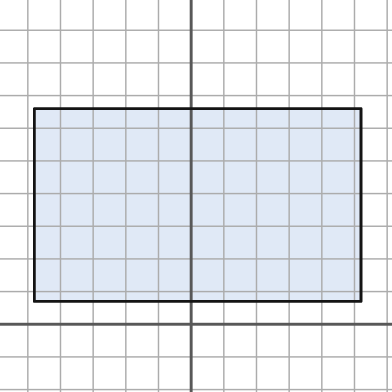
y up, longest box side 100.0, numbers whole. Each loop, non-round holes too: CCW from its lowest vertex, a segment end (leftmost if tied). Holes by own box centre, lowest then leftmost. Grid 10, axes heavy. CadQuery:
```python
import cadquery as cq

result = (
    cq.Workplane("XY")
    .moveTo(-48.0, 7.0)
    .lineTo(52.0, 7.0)
    .lineTo(52.0, 66.0)
    .lineTo(-48.0, 66.0)
    .close()
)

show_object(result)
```